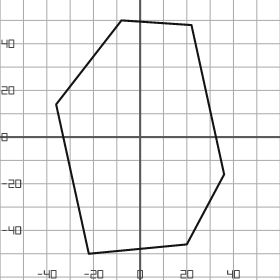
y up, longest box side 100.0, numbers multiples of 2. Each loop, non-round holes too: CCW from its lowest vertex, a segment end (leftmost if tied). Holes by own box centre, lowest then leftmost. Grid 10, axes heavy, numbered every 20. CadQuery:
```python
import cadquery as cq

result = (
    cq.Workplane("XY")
    .moveTo(-22.0, -50.0)
    .lineTo(20.0, -46.0)
    .lineTo(36.0, -16.0)
    .lineTo(22.0, 48.0)
    .lineTo(-8.0, 50.0)
    .lineTo(-36.0, 14.0)
    .close()
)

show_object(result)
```